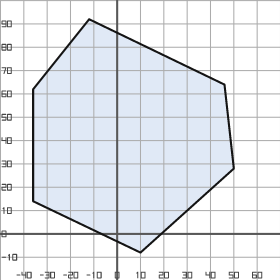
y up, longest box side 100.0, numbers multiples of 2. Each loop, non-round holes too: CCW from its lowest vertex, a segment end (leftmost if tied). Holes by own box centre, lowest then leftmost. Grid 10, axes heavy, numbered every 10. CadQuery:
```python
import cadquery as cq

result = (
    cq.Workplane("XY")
    .moveTo(10.0, -8.0)
    .lineTo(50.0, 28.0)
    .lineTo(46.0, 64.0)
    .lineTo(-12.0, 92.0)
    .lineTo(-36.0, 62.0)
    .lineTo(-36.0, 14.0)
    .close()
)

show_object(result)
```